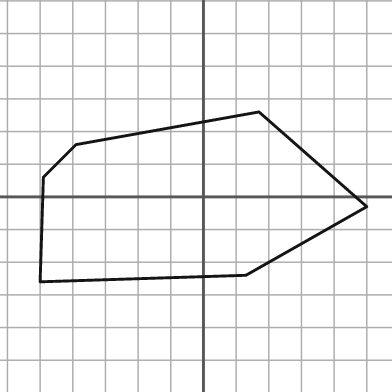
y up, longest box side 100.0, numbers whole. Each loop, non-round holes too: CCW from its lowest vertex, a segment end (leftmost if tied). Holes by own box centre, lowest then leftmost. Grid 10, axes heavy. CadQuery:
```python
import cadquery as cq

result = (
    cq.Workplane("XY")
    .moveTo(-50.0, -26.0)
    .lineTo(13.0, -24.0)
    .lineTo(50.0, -3.0)
    .lineTo(17.0, 26.0)
    .lineTo(-39.0, 16.0)
    .lineTo(-49.0, 6.0)
    .close()
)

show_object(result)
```